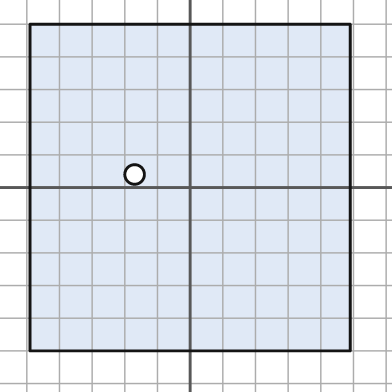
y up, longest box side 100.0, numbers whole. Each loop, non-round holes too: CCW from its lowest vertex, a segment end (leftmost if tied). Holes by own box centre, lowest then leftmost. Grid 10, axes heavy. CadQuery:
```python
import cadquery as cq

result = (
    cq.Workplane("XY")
    .moveTo(-49.0, -50.0)
    .lineTo(49.0, -50.0)
    .lineTo(49.0, 50.0)
    .lineTo(-49.0, 50.0)
    .close()
    .moveTo(-17.0, 4.0)
    .circle(3.0)
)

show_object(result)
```